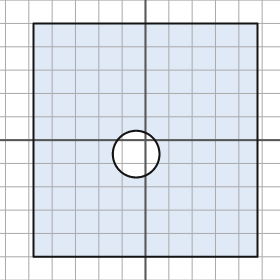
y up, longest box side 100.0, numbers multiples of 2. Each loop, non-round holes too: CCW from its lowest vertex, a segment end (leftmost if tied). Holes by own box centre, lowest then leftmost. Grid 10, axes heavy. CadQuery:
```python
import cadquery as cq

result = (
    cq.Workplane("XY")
    .moveTo(-48.0, -50.0)
    .lineTo(48.0, -50.0)
    .lineTo(48.0, 50.0)
    .lineTo(-48.0, 50.0)
    .close()
    .moveTo(-4.0, -6.0)
    .circle(10.0)
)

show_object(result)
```